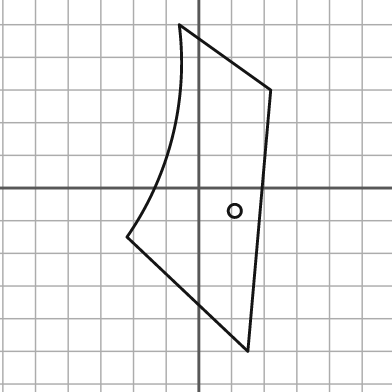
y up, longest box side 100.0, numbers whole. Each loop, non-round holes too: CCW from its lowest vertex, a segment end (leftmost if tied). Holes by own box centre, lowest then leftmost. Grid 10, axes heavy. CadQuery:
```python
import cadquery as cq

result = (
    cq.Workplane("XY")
    .moveTo(15.0, -50.0)
    .lineTo(22.0, 30.0)
    .lineTo(-6.0, 50.0)
    .threePointArc((-8.0, 16.0), (-22.0, -15.0))
    .close()
    .moveTo(11.0, -7.0)
    .circle(2.0)
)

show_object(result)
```